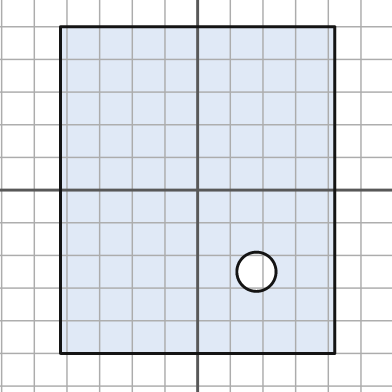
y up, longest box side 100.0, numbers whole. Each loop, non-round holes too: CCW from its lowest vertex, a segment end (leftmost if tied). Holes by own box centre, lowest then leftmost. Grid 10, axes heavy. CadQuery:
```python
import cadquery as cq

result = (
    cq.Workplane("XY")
    .moveTo(-42.0, -50.0)
    .lineTo(42.0, -50.0)
    .lineTo(42.0, 50.0)
    .lineTo(-42.0, 50.0)
    .close()
    .moveTo(18.0, -25.0)
    .circle(6.0)
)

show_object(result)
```